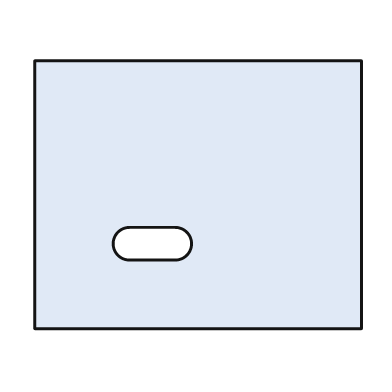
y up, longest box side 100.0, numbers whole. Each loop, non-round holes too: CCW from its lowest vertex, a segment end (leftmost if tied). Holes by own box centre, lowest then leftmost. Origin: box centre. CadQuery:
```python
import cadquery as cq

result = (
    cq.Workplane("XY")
    .moveTo(-50.0, -41.0)
    .lineTo(50.0, -41.0)
    .lineTo(50.0, 41.0)
    .lineTo(-50.0, 41.0)
    .close()
    .moveTo(-21.0, -20.0)
    .lineTo(-7.0, -20.0)
    .threePointArc((-2.0, -15.0), (-7.0, -10.0))
    .lineTo(-21.0, -10.0)
    .threePointArc((-26.0, -15.0), (-21.0, -20.0))
    .close()
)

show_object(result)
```